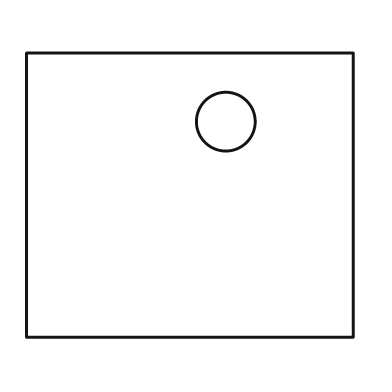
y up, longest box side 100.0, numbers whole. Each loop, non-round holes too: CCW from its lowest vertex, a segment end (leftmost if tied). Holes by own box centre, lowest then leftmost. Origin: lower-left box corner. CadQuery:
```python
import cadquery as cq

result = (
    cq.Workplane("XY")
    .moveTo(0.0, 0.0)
    .lineTo(100.0, 0.0)
    .lineTo(100.0, 87.0)
    .lineTo(0.0, 87.0)
    .close()
    .moveTo(61.0, 66.0)
    .circle(9.0)
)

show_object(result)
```